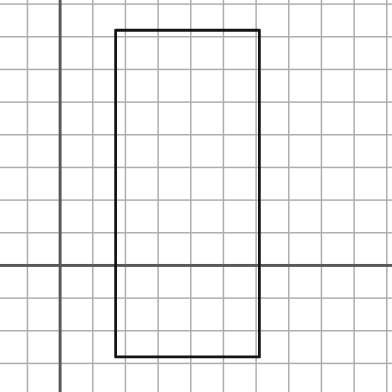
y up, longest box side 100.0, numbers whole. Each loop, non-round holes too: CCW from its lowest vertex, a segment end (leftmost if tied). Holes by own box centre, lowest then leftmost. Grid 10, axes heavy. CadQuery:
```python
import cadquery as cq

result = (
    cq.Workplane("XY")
    .moveTo(17.0, -28.0)
    .lineTo(61.0, -28.0)
    .lineTo(61.0, 72.0)
    .lineTo(17.0, 72.0)
    .close()
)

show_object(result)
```